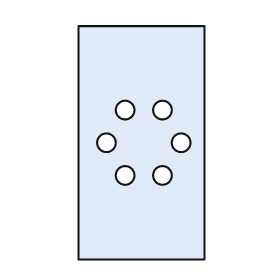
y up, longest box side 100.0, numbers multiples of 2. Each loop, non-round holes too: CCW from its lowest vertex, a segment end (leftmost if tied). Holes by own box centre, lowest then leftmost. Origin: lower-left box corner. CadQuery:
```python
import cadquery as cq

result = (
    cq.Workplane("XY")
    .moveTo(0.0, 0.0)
    .lineTo(54.0, 0.0)
    .lineTo(54.0, 100.0)
    .lineTo(0.0, 100.0)
    .close()
    .moveTo(20.0, 36.0)
    .circle(4.0)
    .moveTo(36.0, 36.0)
    .circle(4.0)
    .moveTo(12.0, 50.0)
    .circle(4.0)
    .moveTo(44.0, 50.0)
    .circle(4.0)
    .moveTo(20.0, 64.0)
    .circle(4.0)
    .moveTo(36.0, 64.0)
    .circle(4.0)
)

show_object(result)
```